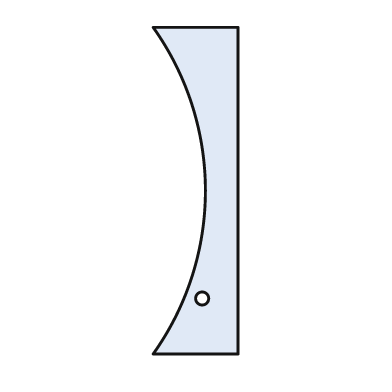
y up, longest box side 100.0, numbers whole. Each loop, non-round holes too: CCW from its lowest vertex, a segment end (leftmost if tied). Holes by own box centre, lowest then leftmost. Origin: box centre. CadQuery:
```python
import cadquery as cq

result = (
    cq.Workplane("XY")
    .moveTo(-13.0, -50.0)
    .lineTo(13.0, -50.0)
    .lineTo(13.0, 50.0)
    .lineTo(-13.0, 50.0)
    .threePointArc((3.0, 0.0), (-13.0, -50.0))
    .close()
    .moveTo(2.0, -33.0)
    .circle(2.0)
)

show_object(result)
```